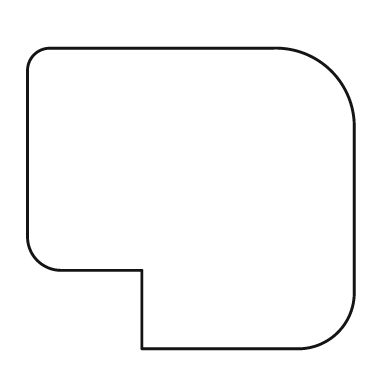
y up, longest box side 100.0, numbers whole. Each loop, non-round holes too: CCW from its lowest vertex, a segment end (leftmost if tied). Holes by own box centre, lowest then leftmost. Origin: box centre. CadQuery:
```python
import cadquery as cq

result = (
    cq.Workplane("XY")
    .moveTo(-15.0, -46.0)
    .lineTo(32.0, -46.0)
    .threePointArc((45.0, -41.0), (50.0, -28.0))
    .lineTo(50.0, 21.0)
    .threePointArc((43.0, 39.0), (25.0, 46.0))
    .lineTo(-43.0, 46.0)
    .threePointArc((-48.0, 44.0), (-50.0, 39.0))
    .lineTo(-50.0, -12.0)
    .threePointArc((-47.0, -19.0), (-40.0, -22.0))
    .lineTo(-15.0, -22.0)
    .close()
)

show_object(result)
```